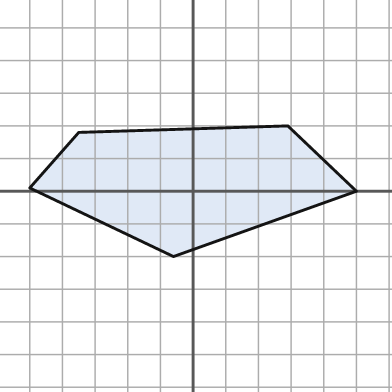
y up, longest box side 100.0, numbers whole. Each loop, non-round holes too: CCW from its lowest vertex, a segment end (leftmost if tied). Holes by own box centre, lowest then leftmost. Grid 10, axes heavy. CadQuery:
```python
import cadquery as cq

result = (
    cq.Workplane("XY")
    .moveTo(-6.0, -20.0)
    .lineTo(50.0, 0.0)
    .lineTo(29.0, 20.0)
    .lineTo(-35.0, 18.0)
    .lineTo(-50.0, 1.0)
    .close()
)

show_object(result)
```